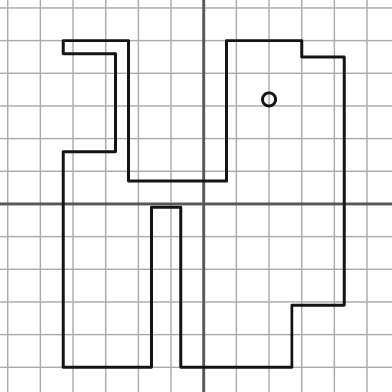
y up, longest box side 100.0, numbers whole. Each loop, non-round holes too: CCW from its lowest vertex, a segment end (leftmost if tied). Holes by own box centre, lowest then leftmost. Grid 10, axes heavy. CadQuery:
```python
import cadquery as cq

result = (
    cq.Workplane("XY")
    .moveTo(-43.0, -50.0)
    .lineTo(-16.0, -50.0)
    .lineTo(-16.0, -1.0)
    .lineTo(-7.0, -1.0)
    .lineTo(-7.0, -50.0)
    .lineTo(27.0, -50.0)
    .lineTo(27.0, -31.0)
    .lineTo(43.0, -31.0)
    .lineTo(43.0, 45.0)
    .lineTo(30.0, 45.0)
    .lineTo(30.0, 50.0)
    .lineTo(7.0, 50.0)
    .lineTo(7.0, 7.0)
    .lineTo(-23.0, 7.0)
    .lineTo(-23.0, 50.0)
    .lineTo(-43.0, 50.0)
    .lineTo(-43.0, 46.0)
    .lineTo(-27.0, 46.0)
    .lineTo(-27.0, 16.0)
    .lineTo(-43.0, 16.0)
    .close()
    .moveTo(20.0, 32.0)
    .circle(2.0)
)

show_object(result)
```